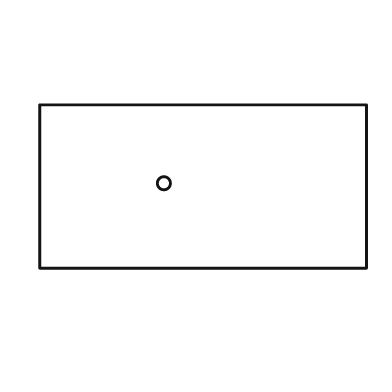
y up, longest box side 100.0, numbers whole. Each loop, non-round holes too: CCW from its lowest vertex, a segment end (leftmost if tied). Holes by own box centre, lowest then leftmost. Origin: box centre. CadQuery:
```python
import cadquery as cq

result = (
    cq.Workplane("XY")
    .moveTo(-50.0, -25.0)
    .lineTo(50.0, -25.0)
    .lineTo(50.0, 25.0)
    .lineTo(-50.0, 25.0)
    .close()
    .moveTo(-12.0, 1.0)
    .circle(2.0)
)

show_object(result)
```